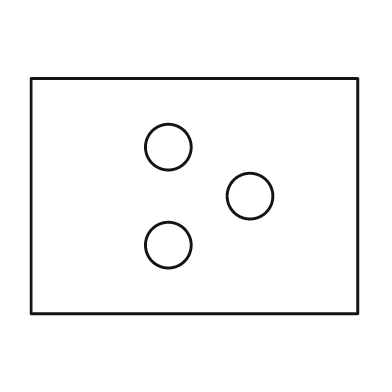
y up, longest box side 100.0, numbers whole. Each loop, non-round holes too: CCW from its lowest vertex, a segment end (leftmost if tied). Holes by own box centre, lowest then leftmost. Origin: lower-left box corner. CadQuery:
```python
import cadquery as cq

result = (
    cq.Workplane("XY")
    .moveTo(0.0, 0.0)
    .lineTo(100.0, 0.0)
    .lineTo(100.0, 72.0)
    .lineTo(0.0, 72.0)
    .close()
    .moveTo(42.0, 21.0)
    .circle(7.0)
    .moveTo(67.0, 36.0)
    .circle(7.0)
    .moveTo(42.0, 51.0)
    .circle(7.0)
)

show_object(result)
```